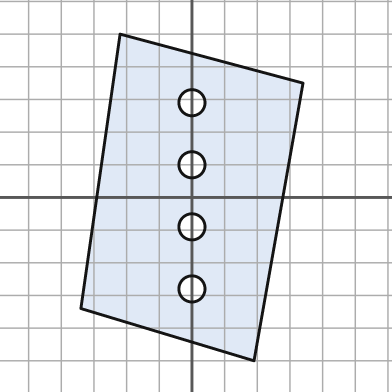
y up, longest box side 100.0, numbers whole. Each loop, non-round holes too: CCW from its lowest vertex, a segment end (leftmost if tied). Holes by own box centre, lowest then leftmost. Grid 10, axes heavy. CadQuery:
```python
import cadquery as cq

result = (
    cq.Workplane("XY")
    .moveTo(19.0, -50.0)
    .lineTo(34.0, 35.0)
    .lineTo(-22.0, 50.0)
    .lineTo(-34.0, -34.0)
    .close()
    .moveTo(0.0, -28.0)
    .circle(4.0)
    .moveTo(0.0, -9.0)
    .circle(4.0)
    .moveTo(0.0, 10.0)
    .circle(4.0)
    .moveTo(0.0, 29.0)
    .circle(4.0)
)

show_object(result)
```